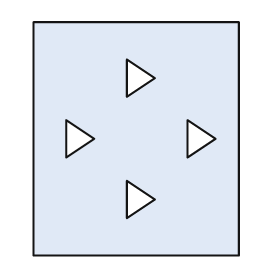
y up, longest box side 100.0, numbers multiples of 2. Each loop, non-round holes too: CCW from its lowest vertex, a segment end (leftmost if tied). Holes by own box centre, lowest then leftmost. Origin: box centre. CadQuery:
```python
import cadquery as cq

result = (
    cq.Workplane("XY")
    .moveTo(-44.0, -50.0)
    .lineTo(44.0, -50.0)
    .lineTo(44.0, 50.0)
    .lineTo(-44.0, 50.0)
    .close()
    .moveTo(-4.0, -34.0)
    .lineTo(8.0, -26.0)
    .lineTo(-4.0, -18.0)
    .close()
    .moveTo(-30.0, -8.0)
    .lineTo(-18.0, 0.0)
    .lineTo(-30.0, 8.0)
    .close()
    .moveTo(22.0, -8.0)
    .lineTo(34.0, 0.0)
    .lineTo(22.0, 8.0)
    .close()
    .moveTo(-4.0, 18.0)
    .lineTo(8.0, 26.0)
    .lineTo(-4.0, 34.0)
    .close()
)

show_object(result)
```